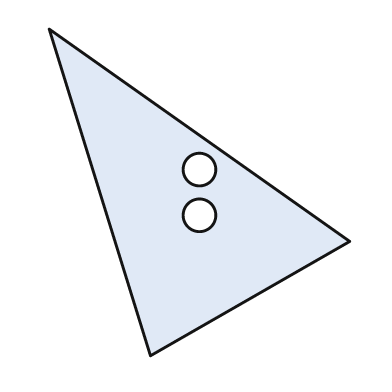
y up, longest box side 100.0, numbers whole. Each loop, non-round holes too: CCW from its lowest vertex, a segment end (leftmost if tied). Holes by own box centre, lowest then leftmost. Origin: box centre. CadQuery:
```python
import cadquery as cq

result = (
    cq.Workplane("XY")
    .moveTo(-15.0, -50.0)
    .lineTo(46.0, -15.0)
    .lineTo(-46.0, 50.0)
    .close()
    .moveTo(0.0, -7.0)
    .circle(5.0)
    .moveTo(0.0, 7.0)
    .circle(5.0)
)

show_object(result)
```